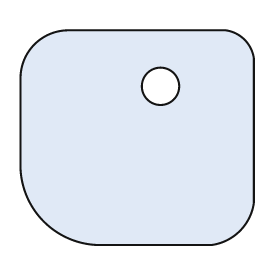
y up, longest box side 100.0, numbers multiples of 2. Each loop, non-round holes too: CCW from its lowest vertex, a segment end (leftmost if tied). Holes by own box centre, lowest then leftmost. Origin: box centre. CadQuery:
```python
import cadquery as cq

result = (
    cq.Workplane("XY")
    .moveTo(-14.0, -46.0)
    .lineTo(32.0, -46.0)
    .threePointArc((44.0, -40.0), (50.0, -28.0))
    .lineTo(50.0, 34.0)
    .threePointArc((46.0, 42.0), (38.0, 46.0))
    .lineTo(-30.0, 46.0)
    .threePointArc((-44.0, 40.0), (-50.0, 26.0))
    .lineTo(-50.0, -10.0)
    .threePointArc((-40.0, -36.0), (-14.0, -46.0))
    .close()
    .moveTo(10.0, 22.0)
    .circle(8.0)
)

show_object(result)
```